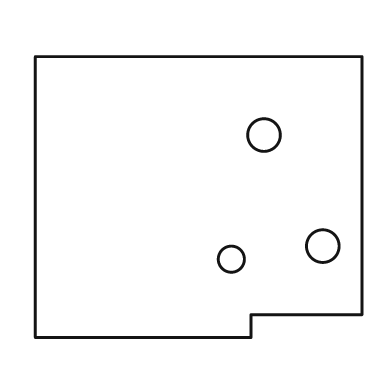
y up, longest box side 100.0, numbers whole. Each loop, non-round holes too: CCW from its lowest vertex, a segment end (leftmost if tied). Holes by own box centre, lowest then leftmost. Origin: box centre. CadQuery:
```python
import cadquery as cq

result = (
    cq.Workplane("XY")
    .moveTo(-50.0, -43.0)
    .lineTo(16.0, -43.0)
    .lineTo(16.0, -36.0)
    .lineTo(50.0, -36.0)
    .lineTo(50.0, 43.0)
    .lineTo(-50.0, 43.0)
    .close()
    .moveTo(10.0, -19.0)
    .circle(4.0)
    .moveTo(38.0, -15.0)
    .circle(5.0)
    .moveTo(20.0, 19.0)
    .circle(5.0)
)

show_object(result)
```